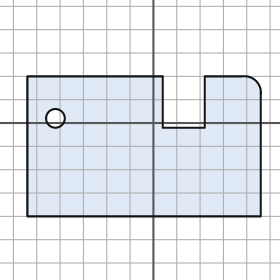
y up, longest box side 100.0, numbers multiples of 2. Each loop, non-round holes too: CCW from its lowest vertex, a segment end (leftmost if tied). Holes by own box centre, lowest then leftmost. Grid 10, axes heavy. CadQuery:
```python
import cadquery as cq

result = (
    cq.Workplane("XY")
    .moveTo(-54.0, -40.0)
    .lineTo(46.0, -40.0)
    .lineTo(46.0, 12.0)
    .threePointArc((44.0, 18.0), (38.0, 20.0))
    .lineTo(22.0, 20.0)
    .lineTo(22.0, -2.0)
    .lineTo(4.0, -2.0)
    .lineTo(4.0, 20.0)
    .lineTo(-54.0, 20.0)
    .close()
    .moveTo(-42.0, 2.0)
    .circle(4.0)
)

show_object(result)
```